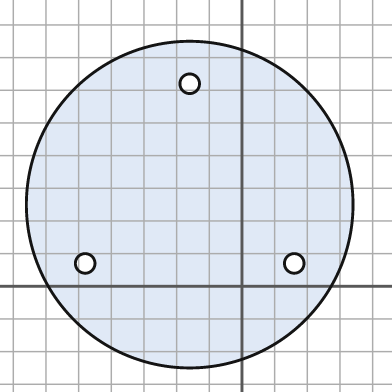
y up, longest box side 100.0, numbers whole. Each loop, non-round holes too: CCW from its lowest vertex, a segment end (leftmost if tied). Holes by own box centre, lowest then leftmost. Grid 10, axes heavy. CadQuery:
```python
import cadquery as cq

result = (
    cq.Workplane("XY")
    .moveTo(-16.0, 25.0)
    .circle(50.0)
    .moveTo(-48.0, 7.0)
    .circle(3.0)
    .moveTo(16.0, 7.0)
    .circle(3.0)
    .moveTo(-16.0, 62.0)
    .circle(3.0)
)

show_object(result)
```